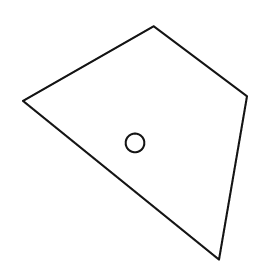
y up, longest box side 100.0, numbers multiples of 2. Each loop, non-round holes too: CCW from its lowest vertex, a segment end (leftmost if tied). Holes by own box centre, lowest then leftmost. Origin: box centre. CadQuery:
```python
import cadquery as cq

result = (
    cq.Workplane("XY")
    .moveTo(36.0, -50.0)
    .lineTo(48.0, 20.0)
    .lineTo(8.0, 50.0)
    .lineTo(-48.0, 18.0)
    .close()
    .moveTo(0.0, 0.0)
    .circle(4.0)
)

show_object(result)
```